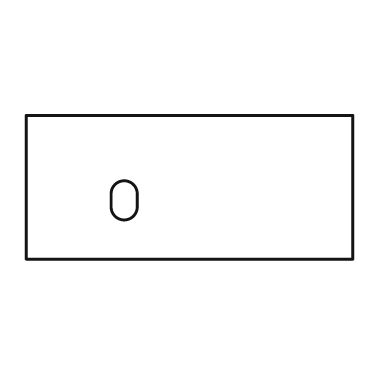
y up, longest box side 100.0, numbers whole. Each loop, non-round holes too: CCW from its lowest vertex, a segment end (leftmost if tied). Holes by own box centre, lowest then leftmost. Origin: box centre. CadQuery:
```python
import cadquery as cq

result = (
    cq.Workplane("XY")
    .moveTo(-50.0, -22.0)
    .lineTo(50.0, -22.0)
    .lineTo(50.0, 22.0)
    .lineTo(-50.0, 22.0)
    .close()
    .moveTo(-24.0, -6.0)
    .threePointArc((-20.0, -10.0), (-16.0, -6.0))
    .lineTo(-16.0, -2.0)
    .threePointArc((-20.0, 2.0), (-24.0, -2.0))
    .close()
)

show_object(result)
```